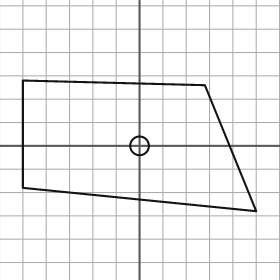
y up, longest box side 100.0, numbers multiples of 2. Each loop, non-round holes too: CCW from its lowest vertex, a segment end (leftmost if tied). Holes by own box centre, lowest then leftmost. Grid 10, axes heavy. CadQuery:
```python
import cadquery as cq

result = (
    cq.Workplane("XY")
    .moveTo(50.0, -28.0)
    .lineTo(28.0, 26.0)
    .lineTo(-50.0, 28.0)
    .lineTo(-50.0, -18.0)
    .close()
    .moveTo(0.0, 0.0)
    .circle(4.0)
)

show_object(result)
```